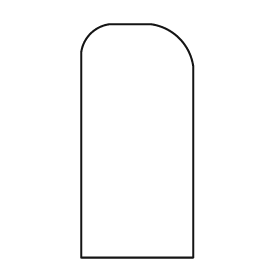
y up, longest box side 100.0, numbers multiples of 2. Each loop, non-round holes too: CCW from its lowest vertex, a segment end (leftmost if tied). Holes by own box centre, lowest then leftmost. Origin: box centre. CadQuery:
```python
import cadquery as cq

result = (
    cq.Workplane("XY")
    .moveTo(-24.0, -50.0)
    .lineTo(24.0, -50.0)
    .lineTo(24.0, 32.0)
    .threePointArc((18.0, 44.0), (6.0, 50.0))
    .lineTo(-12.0, 50.0)
    .threePointArc((-20.0, 46.0), (-24.0, 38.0))
    .close()
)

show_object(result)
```